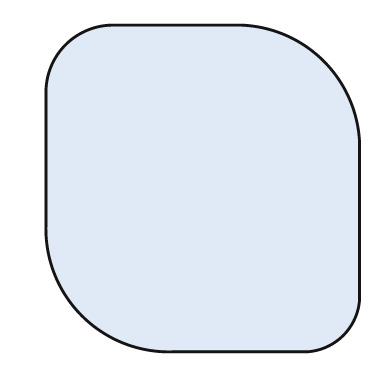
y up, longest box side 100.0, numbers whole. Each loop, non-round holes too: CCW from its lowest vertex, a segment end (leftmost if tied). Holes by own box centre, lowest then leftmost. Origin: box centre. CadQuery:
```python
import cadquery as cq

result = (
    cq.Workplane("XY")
    .moveTo(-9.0, -50.0)
    .lineTo(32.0, -50.0)
    .threePointArc((43.0, -45.0), (48.0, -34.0))
    .lineTo(48.0, 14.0)
    .threePointArc((37.0, 39.0), (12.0, 50.0))
    .lineTo(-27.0, 50.0)
    .threePointArc((-42.0, 44.0), (-48.0, 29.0))
    .lineTo(-48.0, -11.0)
    .threePointArc((-37.0, -39.0), (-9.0, -50.0))
    .close()
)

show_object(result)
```